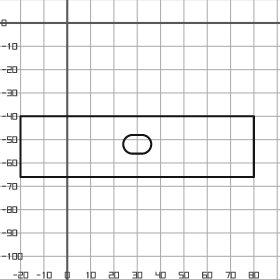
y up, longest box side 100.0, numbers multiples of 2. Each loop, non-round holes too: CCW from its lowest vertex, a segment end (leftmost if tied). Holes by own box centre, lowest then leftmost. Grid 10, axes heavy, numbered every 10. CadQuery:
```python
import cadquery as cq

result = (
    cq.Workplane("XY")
    .moveTo(-20.0, -66.0)
    .lineTo(80.0, -66.0)
    .lineTo(80.0, -40.0)
    .lineTo(-20.0, -40.0)
    .close()
    .moveTo(28.0, -56.0)
    .lineTo(32.0, -56.0)
    .threePointArc((36.0, -52.0), (32.0, -48.0))
    .lineTo(28.0, -48.0)
    .threePointArc((24.0, -52.0), (28.0, -56.0))
    .close()
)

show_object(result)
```